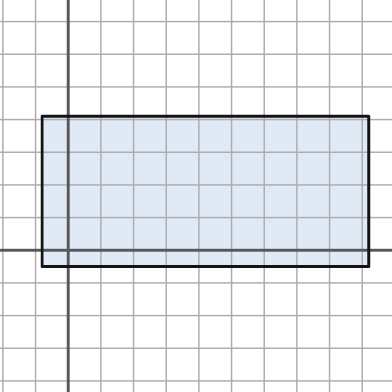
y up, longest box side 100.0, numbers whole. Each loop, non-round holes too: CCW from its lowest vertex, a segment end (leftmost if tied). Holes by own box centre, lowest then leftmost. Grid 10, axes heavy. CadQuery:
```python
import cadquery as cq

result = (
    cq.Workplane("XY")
    .moveTo(-8.0, -5.0)
    .lineTo(92.0, -5.0)
    .lineTo(92.0, 41.0)
    .lineTo(-8.0, 41.0)
    .close()
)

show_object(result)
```